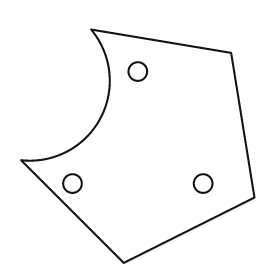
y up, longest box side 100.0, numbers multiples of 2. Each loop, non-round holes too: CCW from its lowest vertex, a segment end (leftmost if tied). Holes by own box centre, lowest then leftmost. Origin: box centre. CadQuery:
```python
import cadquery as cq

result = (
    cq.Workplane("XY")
    .moveTo(-6.0, -50.0)
    .lineTo(50.0, -22.0)
    .lineTo(40.0, 40.0)
    .lineTo(-20.0, 50.0)
    .threePointArc((-16.0, 12.0), (-50.0, -6.0))
    .close()
    .moveTo(-28.0, -16.0)
    .circle(4.0)
    .moveTo(28.0, -16.0)
    .circle(4.0)
    .moveTo(0.0, 32.0)
    .circle(4.0)
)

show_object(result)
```